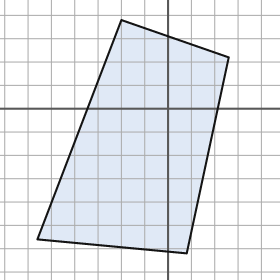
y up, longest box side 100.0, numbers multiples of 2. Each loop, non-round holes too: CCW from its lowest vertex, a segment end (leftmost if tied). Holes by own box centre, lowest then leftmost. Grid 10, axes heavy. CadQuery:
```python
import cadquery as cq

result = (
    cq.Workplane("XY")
    .moveTo(8.0, -62.0)
    .lineTo(26.0, 22.0)
    .lineTo(-20.0, 38.0)
    .lineTo(-56.0, -56.0)
    .close()
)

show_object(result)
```